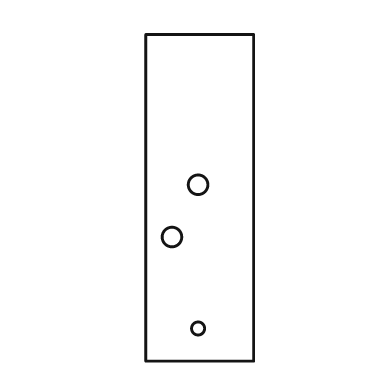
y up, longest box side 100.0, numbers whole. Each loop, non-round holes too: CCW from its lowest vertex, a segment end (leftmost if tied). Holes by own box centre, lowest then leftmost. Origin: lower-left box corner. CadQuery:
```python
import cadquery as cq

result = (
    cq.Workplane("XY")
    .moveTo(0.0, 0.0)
    .lineTo(33.0, 0.0)
    .lineTo(33.0, 100.0)
    .lineTo(0.0, 100.0)
    .close()
    .moveTo(16.0, 10.0)
    .circle(2.0)
    .moveTo(8.0, 38.0)
    .circle(3.0)
    .moveTo(16.0, 54.0)
    .circle(3.0)
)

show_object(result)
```